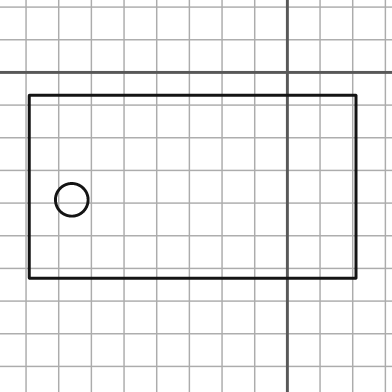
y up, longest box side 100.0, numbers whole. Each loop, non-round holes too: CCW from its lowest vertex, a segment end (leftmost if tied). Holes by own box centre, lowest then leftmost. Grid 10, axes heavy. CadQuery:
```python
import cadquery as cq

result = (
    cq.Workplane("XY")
    .moveTo(-79.0, -63.0)
    .lineTo(21.0, -63.0)
    .lineTo(21.0, -7.0)
    .lineTo(-79.0, -7.0)
    .close()
    .moveTo(-66.0, -39.0)
    .circle(5.0)
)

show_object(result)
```